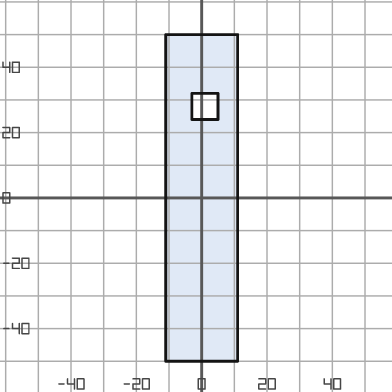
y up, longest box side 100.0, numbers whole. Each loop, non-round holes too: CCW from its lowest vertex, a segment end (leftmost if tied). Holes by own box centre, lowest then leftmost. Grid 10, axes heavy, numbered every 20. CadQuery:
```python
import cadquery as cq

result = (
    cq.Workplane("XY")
    .moveTo(-11.0, -50.0)
    .lineTo(11.0, -50.0)
    .lineTo(11.0, 50.0)
    .lineTo(-11.0, 50.0)
    .close()
    .moveTo(-3.0, 24.0)
    .lineTo(5.0, 24.0)
    .lineTo(5.0, 32.0)
    .lineTo(-3.0, 32.0)
    .close()
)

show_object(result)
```